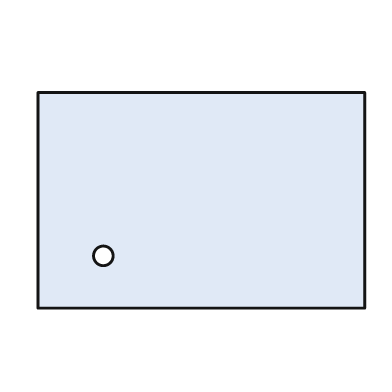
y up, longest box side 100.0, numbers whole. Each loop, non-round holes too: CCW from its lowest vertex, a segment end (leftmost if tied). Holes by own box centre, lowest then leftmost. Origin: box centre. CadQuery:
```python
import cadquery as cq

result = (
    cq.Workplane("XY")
    .moveTo(-50.0, -33.0)
    .lineTo(50.0, -33.0)
    .lineTo(50.0, 33.0)
    .lineTo(-50.0, 33.0)
    .close()
    .moveTo(-30.0, -17.0)
    .circle(3.0)
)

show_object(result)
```